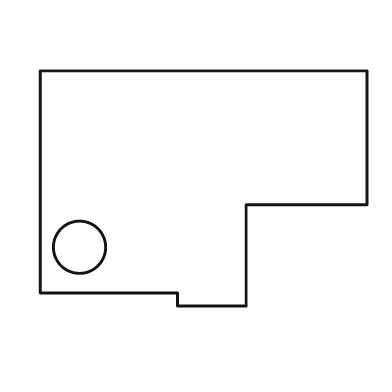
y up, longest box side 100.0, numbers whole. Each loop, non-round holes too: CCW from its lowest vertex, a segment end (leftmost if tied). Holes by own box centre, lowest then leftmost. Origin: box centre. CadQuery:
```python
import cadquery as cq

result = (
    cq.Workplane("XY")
    .moveTo(-8.0, -36.0)
    .lineTo(13.0, -36.0)
    .lineTo(13.0, -5.0)
    .lineTo(50.0, -5.0)
    .lineTo(50.0, 36.0)
    .lineTo(-50.0, 36.0)
    .lineTo(-50.0, -32.0)
    .lineTo(-8.0, -32.0)
    .close()
    .moveTo(-38.0, -18.0)
    .circle(8.0)
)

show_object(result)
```